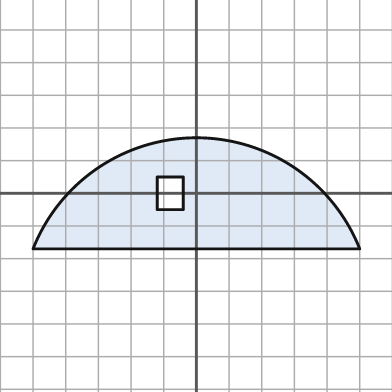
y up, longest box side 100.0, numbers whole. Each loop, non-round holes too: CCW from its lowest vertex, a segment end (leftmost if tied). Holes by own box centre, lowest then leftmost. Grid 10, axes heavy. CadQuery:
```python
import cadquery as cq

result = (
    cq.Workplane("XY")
    .moveTo(-50.0, -17.0)
    .lineTo(50.0, -17.0)
    .threePointArc((0.0, 17.0), (-50.0, -17.0))
    .close()
    .moveTo(-12.0, -5.0)
    .lineTo(-4.0, -5.0)
    .lineTo(-4.0, 5.0)
    .lineTo(-12.0, 5.0)
    .close()
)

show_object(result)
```